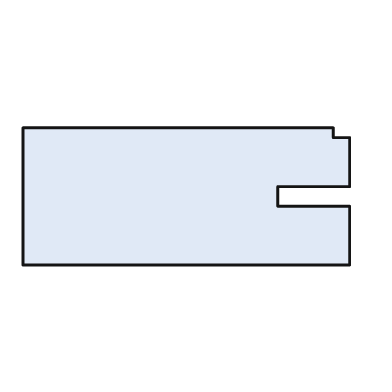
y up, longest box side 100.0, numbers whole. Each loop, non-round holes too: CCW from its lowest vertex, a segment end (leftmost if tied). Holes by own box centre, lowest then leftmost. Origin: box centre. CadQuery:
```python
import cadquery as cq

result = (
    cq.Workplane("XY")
    .moveTo(-50.0, -21.0)
    .lineTo(50.0, -21.0)
    .lineTo(50.0, -3.0)
    .lineTo(28.0, -3.0)
    .lineTo(28.0, 3.0)
    .lineTo(50.0, 3.0)
    .lineTo(50.0, 18.0)
    .lineTo(45.0, 18.0)
    .lineTo(45.0, 21.0)
    .lineTo(-50.0, 21.0)
    .close()
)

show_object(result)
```